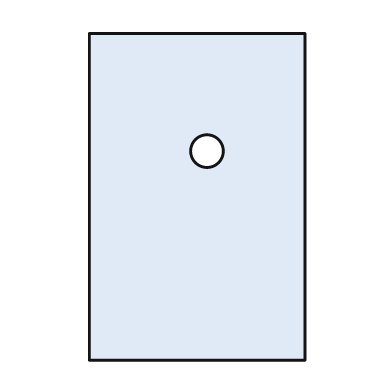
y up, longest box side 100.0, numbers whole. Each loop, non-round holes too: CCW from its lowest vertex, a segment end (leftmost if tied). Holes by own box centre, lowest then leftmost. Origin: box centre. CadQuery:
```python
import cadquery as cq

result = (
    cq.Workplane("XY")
    .moveTo(-33.0, -50.0)
    .lineTo(33.0, -50.0)
    .lineTo(33.0, 50.0)
    .lineTo(-33.0, 50.0)
    .close()
    .moveTo(3.0, 14.0)
    .circle(5.0)
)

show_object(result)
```